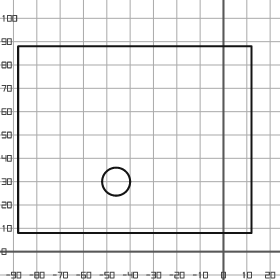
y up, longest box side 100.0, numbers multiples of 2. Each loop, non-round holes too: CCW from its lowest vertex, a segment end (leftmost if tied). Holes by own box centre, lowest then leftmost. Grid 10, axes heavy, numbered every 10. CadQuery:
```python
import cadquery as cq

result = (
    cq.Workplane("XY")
    .moveTo(-88.0, 8.0)
    .lineTo(12.0, 8.0)
    .lineTo(12.0, 88.0)
    .lineTo(-88.0, 88.0)
    .close()
    .moveTo(-46.0, 30.0)
    .circle(6.0)
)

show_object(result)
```